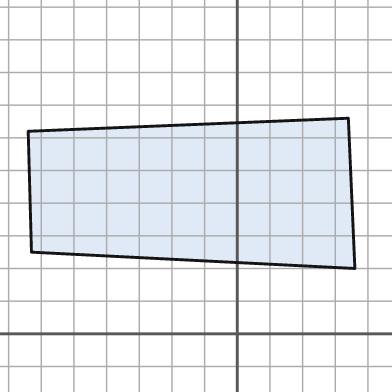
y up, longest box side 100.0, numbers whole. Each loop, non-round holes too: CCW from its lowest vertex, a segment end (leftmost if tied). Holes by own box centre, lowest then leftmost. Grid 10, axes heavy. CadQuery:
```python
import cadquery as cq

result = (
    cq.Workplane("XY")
    .moveTo(36.0, 20.0)
    .lineTo(34.0, 66.0)
    .lineTo(-64.0, 62.0)
    .lineTo(-63.0, 25.0)
    .close()
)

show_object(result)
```